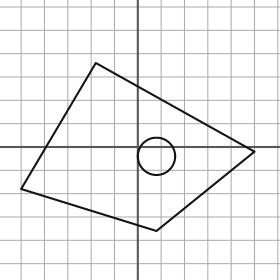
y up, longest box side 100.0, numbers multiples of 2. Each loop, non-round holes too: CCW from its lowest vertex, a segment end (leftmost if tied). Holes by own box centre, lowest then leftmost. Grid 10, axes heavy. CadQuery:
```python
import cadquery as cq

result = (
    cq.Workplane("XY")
    .moveTo(8.0, -36.0)
    .lineTo(50.0, -2.0)
    .lineTo(-18.0, 36.0)
    .lineTo(-50.0, -18.0)
    .close()
    .moveTo(8.0, -4.0)
    .circle(8.0)
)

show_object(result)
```